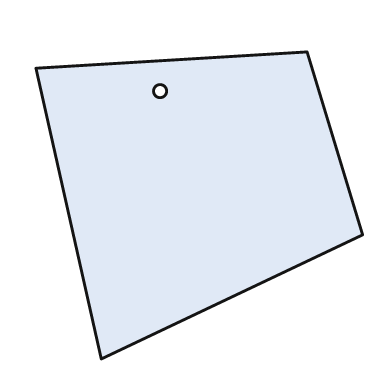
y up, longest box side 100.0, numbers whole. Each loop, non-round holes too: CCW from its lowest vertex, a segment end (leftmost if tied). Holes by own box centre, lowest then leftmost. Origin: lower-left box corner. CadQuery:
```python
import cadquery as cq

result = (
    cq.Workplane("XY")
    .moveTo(20.0, 0.0)
    .lineTo(100.0, 38.0)
    .lineTo(83.0, 94.0)
    .lineTo(0.0, 89.0)
    .close()
    .moveTo(38.0, 82.0)
    .circle(2.0)
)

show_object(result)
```